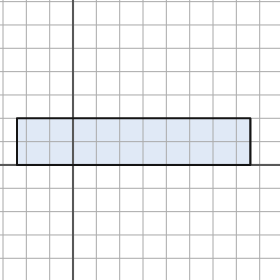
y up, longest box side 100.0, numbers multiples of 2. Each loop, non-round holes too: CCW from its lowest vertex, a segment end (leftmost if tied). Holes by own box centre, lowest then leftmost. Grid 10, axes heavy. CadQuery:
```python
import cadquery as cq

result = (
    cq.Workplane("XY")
    .moveTo(-24.0, 0.0)
    .lineTo(76.0, 0.0)
    .lineTo(76.0, 20.0)
    .lineTo(-24.0, 20.0)
    .close()
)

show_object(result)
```